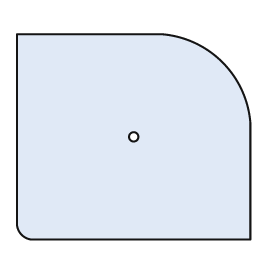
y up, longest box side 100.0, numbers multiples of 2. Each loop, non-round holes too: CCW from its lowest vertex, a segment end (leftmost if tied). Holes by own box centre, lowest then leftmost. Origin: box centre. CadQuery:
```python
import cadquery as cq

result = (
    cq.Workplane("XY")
    .moveTo(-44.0, -44.0)
    .lineTo(50.0, -44.0)
    .lineTo(50.0, 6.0)
    .threePointArc((38.0, 32.0), (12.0, 44.0))
    .lineTo(-50.0, 44.0)
    .lineTo(-50.0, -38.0)
    .threePointArc((-48.0, -42.0), (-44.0, -44.0))
    .close()
    .moveTo(0.0, 0.0)
    .circle(2.0)
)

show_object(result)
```